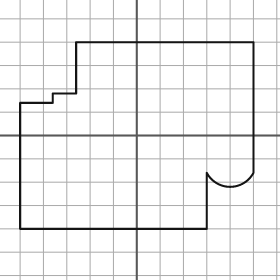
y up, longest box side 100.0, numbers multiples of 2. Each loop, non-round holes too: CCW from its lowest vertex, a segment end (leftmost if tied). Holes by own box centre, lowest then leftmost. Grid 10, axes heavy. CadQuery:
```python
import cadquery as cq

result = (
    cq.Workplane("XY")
    .moveTo(-50.0, -40.0)
    .lineTo(30.0, -40.0)
    .lineTo(30.0, -16.0)
    .threePointArc((40.0, -22.0), (50.0, -16.0))
    .lineTo(50.0, 40.0)
    .lineTo(-26.0, 40.0)
    .lineTo(-26.0, 18.0)
    .lineTo(-36.0, 18.0)
    .lineTo(-36.0, 14.0)
    .lineTo(-50.0, 14.0)
    .close()
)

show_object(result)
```